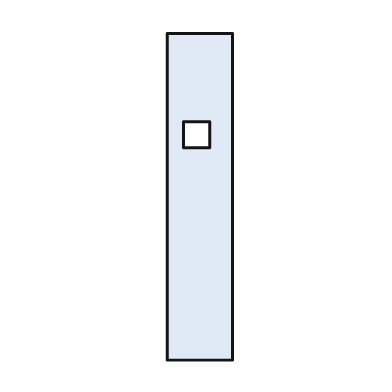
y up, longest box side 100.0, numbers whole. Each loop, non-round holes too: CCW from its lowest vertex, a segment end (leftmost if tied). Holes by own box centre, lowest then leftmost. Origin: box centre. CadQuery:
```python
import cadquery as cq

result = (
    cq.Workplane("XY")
    .moveTo(-10.0, -50.0)
    .lineTo(10.0, -50.0)
    .lineTo(10.0, 50.0)
    .lineTo(-10.0, 50.0)
    .close()
    .moveTo(-5.0, 15.0)
    .lineTo(3.0, 15.0)
    .lineTo(3.0, 23.0)
    .lineTo(-5.0, 23.0)
    .close()
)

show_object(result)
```